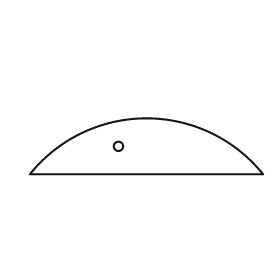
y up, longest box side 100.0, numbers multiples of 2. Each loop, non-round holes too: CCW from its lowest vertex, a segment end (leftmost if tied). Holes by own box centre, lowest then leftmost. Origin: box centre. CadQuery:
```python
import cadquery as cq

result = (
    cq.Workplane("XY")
    .moveTo(-50.0, -12.0)
    .lineTo(50.0, -12.0)
    .threePointArc((0.0, 12.0), (-50.0, -12.0))
    .close()
    .moveTo(-12.0, 0.0)
    .circle(2.0)
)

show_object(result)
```